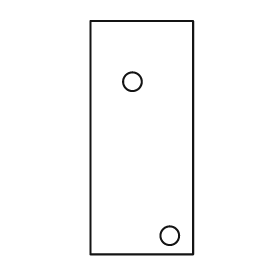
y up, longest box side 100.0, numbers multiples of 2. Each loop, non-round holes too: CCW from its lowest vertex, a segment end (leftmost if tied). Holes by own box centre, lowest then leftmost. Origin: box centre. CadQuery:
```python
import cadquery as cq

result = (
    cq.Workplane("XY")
    .moveTo(-22.0, -50.0)
    .lineTo(22.0, -50.0)
    .lineTo(22.0, 50.0)
    .lineTo(-22.0, 50.0)
    .close()
    .moveTo(12.0, -42.0)
    .circle(4.0)
    .moveTo(-4.0, 24.0)
    .circle(4.0)
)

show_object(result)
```